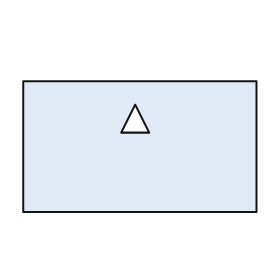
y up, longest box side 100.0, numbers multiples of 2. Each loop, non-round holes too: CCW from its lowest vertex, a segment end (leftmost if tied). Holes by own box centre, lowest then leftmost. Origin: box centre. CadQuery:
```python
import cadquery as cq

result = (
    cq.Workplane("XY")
    .moveTo(-50.0, -28.0)
    .lineTo(50.0, -28.0)
    .lineTo(50.0, 28.0)
    .lineTo(-50.0, 28.0)
    .close()
    .moveTo(-8.0, 6.0)
    .lineTo(4.0, 6.0)
    .lineTo(-2.0, 18.0)
    .close()
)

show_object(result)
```